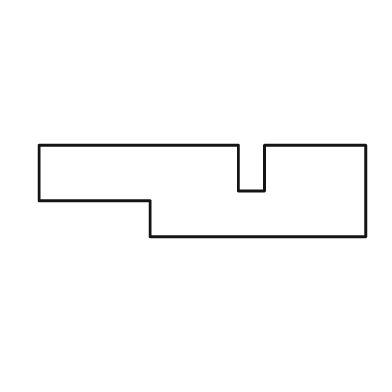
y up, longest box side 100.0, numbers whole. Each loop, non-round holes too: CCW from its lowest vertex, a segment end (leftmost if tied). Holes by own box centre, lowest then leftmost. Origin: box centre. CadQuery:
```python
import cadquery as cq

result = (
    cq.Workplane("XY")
    .moveTo(-16.0, -14.0)
    .lineTo(50.0, -14.0)
    .lineTo(50.0, 14.0)
    .lineTo(19.0, 14.0)
    .lineTo(19.0, 0.0)
    .lineTo(11.0, 0.0)
    .lineTo(11.0, 14.0)
    .lineTo(-50.0, 14.0)
    .lineTo(-50.0, -3.0)
    .lineTo(-16.0, -3.0)
    .close()
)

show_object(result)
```